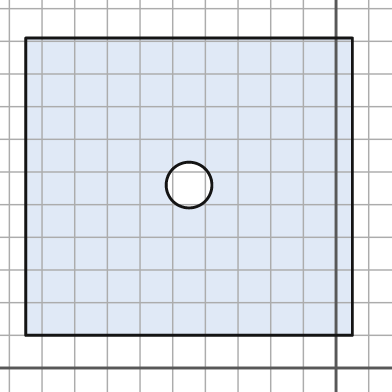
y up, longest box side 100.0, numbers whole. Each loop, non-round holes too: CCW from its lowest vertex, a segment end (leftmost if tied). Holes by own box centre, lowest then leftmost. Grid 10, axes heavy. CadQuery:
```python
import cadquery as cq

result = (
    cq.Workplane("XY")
    .moveTo(-95.0, 10.0)
    .lineTo(5.0, 10.0)
    .lineTo(5.0, 101.0)
    .lineTo(-95.0, 101.0)
    .close()
    .moveTo(-45.0, 56.0)
    .circle(7.0)
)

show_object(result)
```